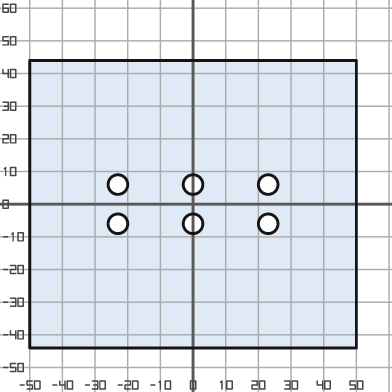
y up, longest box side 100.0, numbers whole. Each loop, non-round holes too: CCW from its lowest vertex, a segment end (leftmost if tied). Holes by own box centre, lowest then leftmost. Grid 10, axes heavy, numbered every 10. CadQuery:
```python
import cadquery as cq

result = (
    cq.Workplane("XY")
    .moveTo(-50.0, -44.0)
    .lineTo(50.0, -44.0)
    .lineTo(50.0, 44.0)
    .lineTo(-50.0, 44.0)
    .close()
    .moveTo(-23.0, -6.0)
    .circle(3.0)
    .moveTo(0.0, -6.0)
    .circle(3.0)
    .moveTo(23.0, -6.0)
    .circle(3.0)
    .moveTo(-23.0, 6.0)
    .circle(3.0)
    .moveTo(0.0, 6.0)
    .circle(3.0)
    .moveTo(23.0, 6.0)
    .circle(3.0)
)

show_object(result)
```